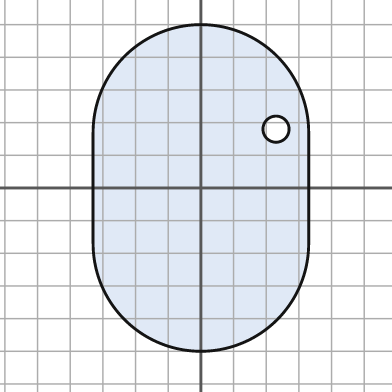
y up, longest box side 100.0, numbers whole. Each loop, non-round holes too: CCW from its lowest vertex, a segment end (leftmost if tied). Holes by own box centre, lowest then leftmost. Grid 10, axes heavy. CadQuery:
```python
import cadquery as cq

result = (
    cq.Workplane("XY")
    .moveTo(-33.0, -17.0)
    .threePointArc((0.0, -50.0), (33.0, -17.0))
    .lineTo(33.0, 17.0)
    .threePointArc((0.0, 50.0), (-33.0, 17.0))
    .close()
    .moveTo(23.0, 18.0)
    .circle(4.0)
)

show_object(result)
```